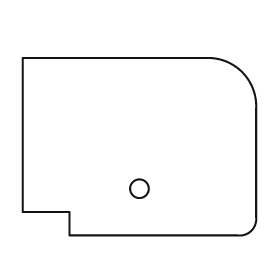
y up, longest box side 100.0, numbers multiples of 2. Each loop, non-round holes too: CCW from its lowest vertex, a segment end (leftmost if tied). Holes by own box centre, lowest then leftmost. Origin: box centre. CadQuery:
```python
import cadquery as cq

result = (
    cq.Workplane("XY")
    .moveTo(-30.0, -38.0)
    .lineTo(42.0, -38.0)
    .threePointArc((48.0, -36.0), (50.0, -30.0))
    .lineTo(50.0, 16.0)
    .threePointArc((44.0, 32.0), (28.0, 38.0))
    .lineTo(-50.0, 38.0)
    .lineTo(-50.0, -28.0)
    .lineTo(-30.0, -28.0)
    .close()
    .moveTo(0.0, -18.0)
    .circle(4.0)
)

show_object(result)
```